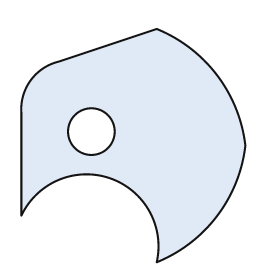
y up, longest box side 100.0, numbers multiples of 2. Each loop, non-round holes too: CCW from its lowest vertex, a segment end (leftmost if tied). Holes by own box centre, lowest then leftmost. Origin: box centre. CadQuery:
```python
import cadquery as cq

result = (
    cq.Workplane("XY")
    .moveTo(10.0, -50.0)
    .threePointArc((36.0, -30.0), (48.0, 0.0))
    .threePointArc((36.0, 30.0), (10.0, 50.0))
    .lineTo(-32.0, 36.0)
    .threePointArc((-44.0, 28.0), (-48.0, 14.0))
    .lineTo(-48.0, -30.0)
    .threePointArc((-10.0, -14.0), (10.0, -50.0))
    .close()
    .moveTo(-18.0, 6.0)
    .circle(10.0)
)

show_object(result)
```